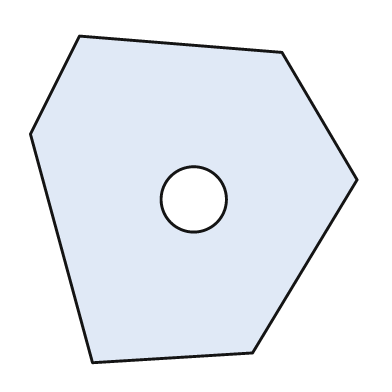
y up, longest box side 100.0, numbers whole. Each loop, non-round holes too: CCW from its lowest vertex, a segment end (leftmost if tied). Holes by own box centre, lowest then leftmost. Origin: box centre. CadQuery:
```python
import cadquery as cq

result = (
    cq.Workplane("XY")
    .moveTo(-31.0, -50.0)
    .lineTo(18.0, -47.0)
    .lineTo(50.0, 6.0)
    .lineTo(27.0, 45.0)
    .lineTo(-35.0, 50.0)
    .lineTo(-50.0, 20.0)
    .close()
    .moveTo(0.0, 0.0)
    .circle(10.0)
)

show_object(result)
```